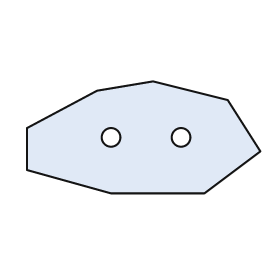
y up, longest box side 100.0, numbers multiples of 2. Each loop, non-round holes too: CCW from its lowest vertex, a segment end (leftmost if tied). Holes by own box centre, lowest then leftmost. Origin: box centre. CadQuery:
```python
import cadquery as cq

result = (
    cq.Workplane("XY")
    .moveTo(-14.0, -24.0)
    .lineTo(26.0, -24.0)
    .lineTo(50.0, -6.0)
    .lineTo(36.0, 16.0)
    .lineTo(4.0, 24.0)
    .lineTo(-20.0, 20.0)
    .lineTo(-50.0, 4.0)
    .lineTo(-50.0, -14.0)
    .close()
    .moveTo(-14.0, 0.0)
    .circle(4.0)
    .moveTo(16.0, 0.0)
    .circle(4.0)
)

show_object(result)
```